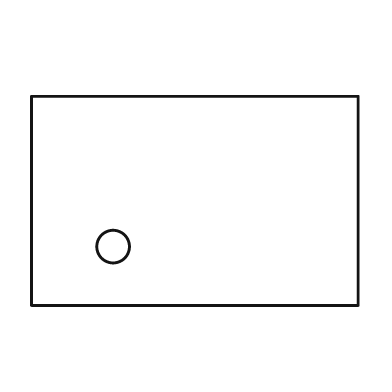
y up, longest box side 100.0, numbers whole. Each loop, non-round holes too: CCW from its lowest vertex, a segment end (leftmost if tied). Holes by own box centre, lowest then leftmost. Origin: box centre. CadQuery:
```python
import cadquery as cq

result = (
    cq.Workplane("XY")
    .moveTo(-50.0, -32.0)
    .lineTo(50.0, -32.0)
    .lineTo(50.0, 32.0)
    .lineTo(-50.0, 32.0)
    .close()
    .moveTo(-25.0, -14.0)
    .circle(5.0)
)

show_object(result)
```